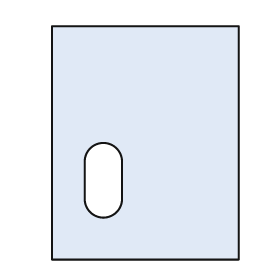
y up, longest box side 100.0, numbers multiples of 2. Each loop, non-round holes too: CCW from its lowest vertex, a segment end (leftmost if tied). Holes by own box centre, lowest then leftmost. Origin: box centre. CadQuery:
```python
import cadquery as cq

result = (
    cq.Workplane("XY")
    .moveTo(-40.0, -50.0)
    .lineTo(40.0, -50.0)
    .lineTo(40.0, 50.0)
    .lineTo(-40.0, 50.0)
    .close()
    .moveTo(-26.0, -24.0)
    .threePointArc((-18.0, -32.0), (-10.0, -24.0))
    .lineTo(-10.0, -8.0)
    .threePointArc((-18.0, 0.0), (-26.0, -8.0))
    .close()
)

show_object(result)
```